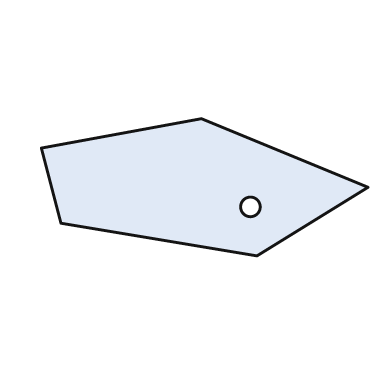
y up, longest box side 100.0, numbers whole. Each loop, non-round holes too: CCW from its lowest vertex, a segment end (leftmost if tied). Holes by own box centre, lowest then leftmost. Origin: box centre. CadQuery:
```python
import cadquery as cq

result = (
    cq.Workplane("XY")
    .moveTo(16.0, -21.0)
    .lineTo(50.0, 0.0)
    .lineTo(-1.0, 21.0)
    .lineTo(-50.0, 12.0)
    .lineTo(-44.0, -11.0)
    .close()
    .moveTo(14.0, -6.0)
    .circle(3.0)
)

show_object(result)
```